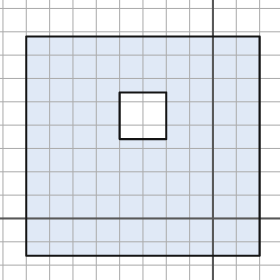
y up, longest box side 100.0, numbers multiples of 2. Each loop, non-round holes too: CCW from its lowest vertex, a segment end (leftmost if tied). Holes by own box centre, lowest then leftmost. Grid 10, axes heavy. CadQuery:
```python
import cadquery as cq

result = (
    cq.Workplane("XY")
    .moveTo(-80.0, -16.0)
    .lineTo(20.0, -16.0)
    .lineTo(20.0, 78.0)
    .lineTo(-80.0, 78.0)
    .close()
    .moveTo(-40.0, 34.0)
    .lineTo(-20.0, 34.0)
    .lineTo(-20.0, 54.0)
    .lineTo(-40.0, 54.0)
    .close()
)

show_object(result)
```